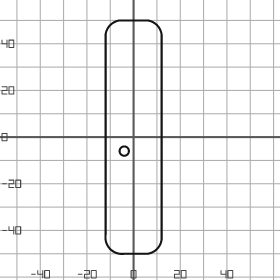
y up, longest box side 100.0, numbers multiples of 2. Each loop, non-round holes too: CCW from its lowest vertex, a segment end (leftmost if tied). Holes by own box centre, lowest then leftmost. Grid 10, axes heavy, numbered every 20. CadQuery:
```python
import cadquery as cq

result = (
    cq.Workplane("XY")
    .moveTo(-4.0, -50.0)
    .lineTo(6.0, -50.0)
    .threePointArc((10.0, -48.0), (12.0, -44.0))
    .lineTo(12.0, 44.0)
    .threePointArc((10.0, 48.0), (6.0, 50.0))
    .lineTo(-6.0, 50.0)
    .threePointArc((-10.0, 48.0), (-12.0, 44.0))
    .lineTo(-12.0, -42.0)
    .threePointArc((-10.0, -48.0), (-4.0, -50.0))
    .close()
    .moveTo(-4.0, -6.0)
    .circle(2.0)
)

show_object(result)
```